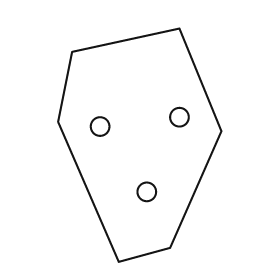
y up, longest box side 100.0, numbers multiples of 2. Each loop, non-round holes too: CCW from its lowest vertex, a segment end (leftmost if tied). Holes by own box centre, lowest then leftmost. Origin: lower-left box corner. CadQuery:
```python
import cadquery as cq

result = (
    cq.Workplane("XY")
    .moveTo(26.0, 0.0)
    .lineTo(48.0, 6.0)
    .lineTo(70.0, 56.0)
    .lineTo(52.0, 100.0)
    .lineTo(6.0, 90.0)
    .lineTo(0.0, 60.0)
    .close()
    .moveTo(38.0, 30.0)
    .circle(4.0)
    .moveTo(18.0, 58.0)
    .circle(4.0)
    .moveTo(52.0, 62.0)
    .circle(4.0)
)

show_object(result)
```